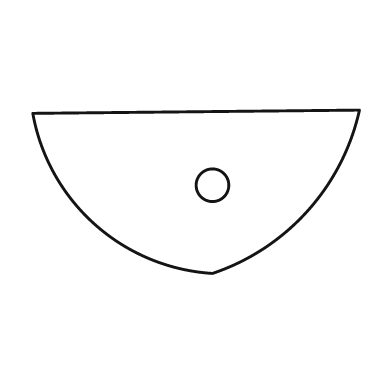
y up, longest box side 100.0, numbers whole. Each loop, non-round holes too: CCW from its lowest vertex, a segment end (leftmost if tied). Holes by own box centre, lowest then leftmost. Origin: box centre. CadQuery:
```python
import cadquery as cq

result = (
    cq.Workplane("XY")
    .moveTo(5.0, -25.0)
    .threePointArc((34.0, -6.0), (50.0, 25.0))
    .lineTo(-50.0, 24.0)
    .threePointArc((-31.0, -10.0), (5.0, -25.0))
    .close()
    .moveTo(5.0, 2.0)
    .circle(5.0)
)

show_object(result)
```